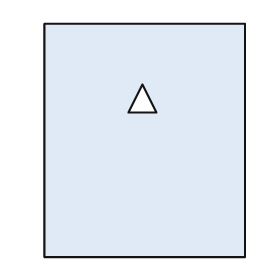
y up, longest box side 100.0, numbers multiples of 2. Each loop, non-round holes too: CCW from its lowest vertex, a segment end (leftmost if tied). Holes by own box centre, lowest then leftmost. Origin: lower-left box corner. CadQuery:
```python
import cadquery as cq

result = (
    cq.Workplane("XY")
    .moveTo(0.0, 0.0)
    .lineTo(86.0, 0.0)
    .lineTo(86.0, 100.0)
    .lineTo(0.0, 100.0)
    .close()
    .moveTo(36.0, 62.0)
    .lineTo(48.0, 62.0)
    .lineTo(42.0, 74.0)
    .close()
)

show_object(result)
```